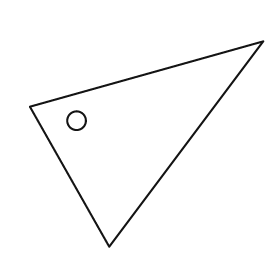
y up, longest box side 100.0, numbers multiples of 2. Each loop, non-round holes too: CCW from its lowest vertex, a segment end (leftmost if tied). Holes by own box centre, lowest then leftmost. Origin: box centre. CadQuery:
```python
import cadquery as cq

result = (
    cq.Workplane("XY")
    .moveTo(-16.0, -44.0)
    .lineTo(50.0, 44.0)
    .lineTo(-50.0, 16.0)
    .close()
    .moveTo(-30.0, 10.0)
    .circle(4.0)
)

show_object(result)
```